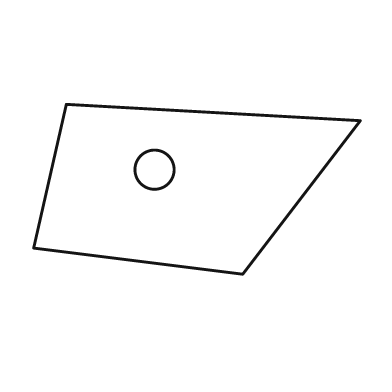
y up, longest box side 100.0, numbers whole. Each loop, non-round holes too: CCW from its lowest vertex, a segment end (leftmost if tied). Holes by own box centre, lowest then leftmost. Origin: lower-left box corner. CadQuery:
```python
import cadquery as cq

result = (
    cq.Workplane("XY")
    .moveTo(64.0, 0.0)
    .lineTo(100.0, 47.0)
    .lineTo(10.0, 52.0)
    .lineTo(0.0, 8.0)
    .close()
    .moveTo(37.0, 32.0)
    .circle(6.0)
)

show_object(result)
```